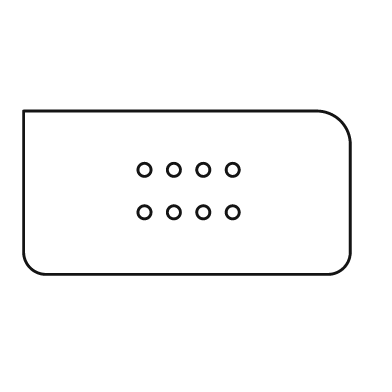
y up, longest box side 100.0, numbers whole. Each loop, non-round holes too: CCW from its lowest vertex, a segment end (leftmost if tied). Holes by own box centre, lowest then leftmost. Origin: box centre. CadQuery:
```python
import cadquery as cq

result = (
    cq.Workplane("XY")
    .moveTo(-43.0, -25.0)
    .lineTo(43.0, -25.0)
    .threePointArc((48.0, -23.0), (50.0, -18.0))
    .lineTo(50.0, 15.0)
    .threePointArc((47.0, 22.0), (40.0, 25.0))
    .lineTo(-50.0, 25.0)
    .lineTo(-50.0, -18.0)
    .threePointArc((-48.0, -23.0), (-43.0, -25.0))
    .close()
    .moveTo(-13.0, -6.0)
    .circle(2.0)
    .moveTo(-4.0, -6.0)
    .circle(2.0)
    .moveTo(5.0, -6.0)
    .circle(2.0)
    .moveTo(14.0, -6.0)
    .circle(2.0)
    .moveTo(-13.0, 7.0)
    .circle(2.0)
    .moveTo(-4.0, 7.0)
    .circle(2.0)
    .moveTo(5.0, 7.0)
    .circle(2.0)
    .moveTo(14.0, 7.0)
    .circle(2.0)
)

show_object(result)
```